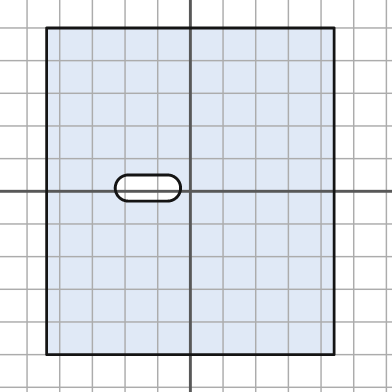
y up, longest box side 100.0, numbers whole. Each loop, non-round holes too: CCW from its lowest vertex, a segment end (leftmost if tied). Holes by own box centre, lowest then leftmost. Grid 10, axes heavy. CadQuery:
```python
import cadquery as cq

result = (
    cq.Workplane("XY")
    .moveTo(-44.0, -50.0)
    .lineTo(44.0, -50.0)
    .lineTo(44.0, 50.0)
    .lineTo(-44.0, 50.0)
    .close()
    .moveTo(-19.0, -3.0)
    .lineTo(-7.0, -3.0)
    .threePointArc((-3.0, 1.0), (-7.0, 5.0))
    .lineTo(-19.0, 5.0)
    .threePointArc((-23.0, 1.0), (-19.0, -3.0))
    .close()
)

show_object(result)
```